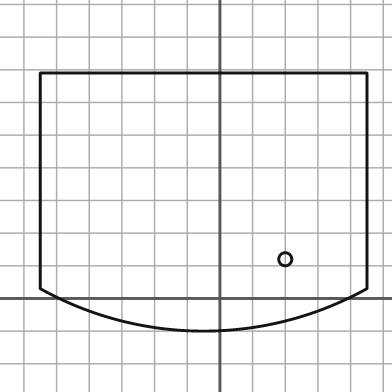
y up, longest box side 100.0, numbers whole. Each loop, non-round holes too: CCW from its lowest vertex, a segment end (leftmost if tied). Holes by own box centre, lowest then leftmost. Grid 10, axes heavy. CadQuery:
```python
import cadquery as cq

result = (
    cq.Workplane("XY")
    .moveTo(-55.0, 3.0)
    .threePointArc((-5.0, -10.0), (45.0, 3.0))
    .lineTo(45.0, 69.0)
    .lineTo(-55.0, 69.0)
    .close()
    .moveTo(20.0, 12.0)
    .circle(2.0)
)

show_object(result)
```